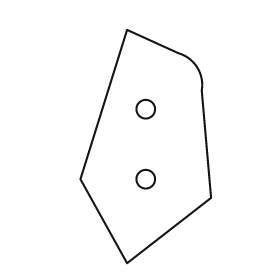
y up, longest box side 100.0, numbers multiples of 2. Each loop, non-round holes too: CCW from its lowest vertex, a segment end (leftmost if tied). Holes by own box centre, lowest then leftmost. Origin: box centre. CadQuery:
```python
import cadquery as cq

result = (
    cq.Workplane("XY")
    .moveTo(-8.0, -50.0)
    .lineTo(28.0, -22.0)
    .lineTo(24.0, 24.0)
    .threePointArc((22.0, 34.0), (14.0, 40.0))
    .lineTo(-8.0, 50.0)
    .lineTo(-28.0, -14.0)
    .close()
    .moveTo(0.0, -14.0)
    .circle(4.0)
    .moveTo(0.0, 16.0)
    .circle(4.0)
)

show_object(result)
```